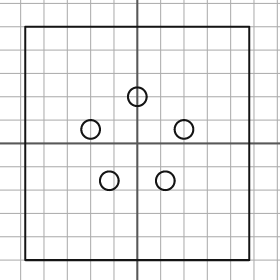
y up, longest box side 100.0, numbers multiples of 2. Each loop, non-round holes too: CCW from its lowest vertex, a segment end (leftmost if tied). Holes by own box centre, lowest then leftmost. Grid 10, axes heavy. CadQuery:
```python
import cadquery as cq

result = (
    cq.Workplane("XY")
    .moveTo(-48.0, -50.0)
    .lineTo(48.0, -50.0)
    .lineTo(48.0, 50.0)
    .lineTo(-48.0, 50.0)
    .close()
    .moveTo(-12.0, -16.0)
    .circle(4.0)
    .moveTo(12.0, -16.0)
    .circle(4.0)
    .moveTo(-20.0, 6.0)
    .circle(4.0)
    .moveTo(20.0, 6.0)
    .circle(4.0)
    .moveTo(0.0, 20.0)
    .circle(4.0)
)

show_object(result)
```